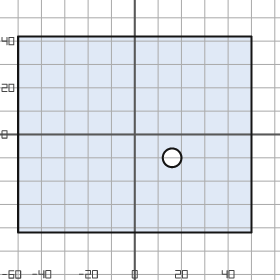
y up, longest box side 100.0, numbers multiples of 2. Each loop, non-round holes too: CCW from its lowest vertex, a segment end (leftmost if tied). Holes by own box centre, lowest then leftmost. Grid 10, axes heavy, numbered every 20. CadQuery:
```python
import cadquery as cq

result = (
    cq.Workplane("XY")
    .moveTo(-50.0, -42.0)
    .lineTo(50.0, -42.0)
    .lineTo(50.0, 42.0)
    .lineTo(-50.0, 42.0)
    .close()
    .moveTo(16.0, -10.0)
    .circle(4.0)
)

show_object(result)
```